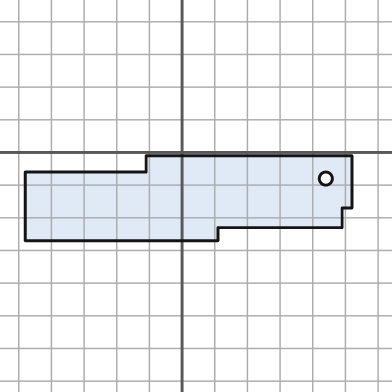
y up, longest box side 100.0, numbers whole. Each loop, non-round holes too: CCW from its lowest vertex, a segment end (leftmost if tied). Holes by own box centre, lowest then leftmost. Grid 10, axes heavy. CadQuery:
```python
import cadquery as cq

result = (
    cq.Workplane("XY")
    .moveTo(-48.0, -27.0)
    .lineTo(11.0, -27.0)
    .lineTo(11.0, -23.0)
    .lineTo(49.0, -23.0)
    .lineTo(49.0, -17.0)
    .lineTo(52.0, -17.0)
    .lineTo(52.0, -1.0)
    .lineTo(-11.0, -1.0)
    .lineTo(-11.0, -6.0)
    .lineTo(-48.0, -6.0)
    .close()
    .moveTo(44.0, -8.0)
    .circle(2.0)
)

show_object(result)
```